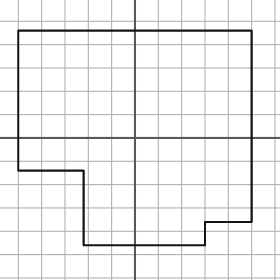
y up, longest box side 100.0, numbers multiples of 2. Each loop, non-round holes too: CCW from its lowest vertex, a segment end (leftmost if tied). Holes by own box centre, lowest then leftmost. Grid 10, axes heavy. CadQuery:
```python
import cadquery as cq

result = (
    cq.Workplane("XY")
    .moveTo(-22.0, -46.0)
    .lineTo(30.0, -46.0)
    .lineTo(30.0, -36.0)
    .lineTo(50.0, -36.0)
    .lineTo(50.0, 46.0)
    .lineTo(-50.0, 46.0)
    .lineTo(-50.0, -14.0)
    .lineTo(-22.0, -14.0)
    .close()
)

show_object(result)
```